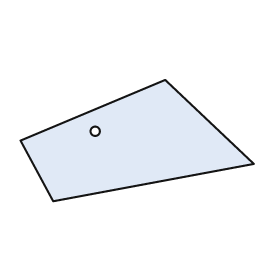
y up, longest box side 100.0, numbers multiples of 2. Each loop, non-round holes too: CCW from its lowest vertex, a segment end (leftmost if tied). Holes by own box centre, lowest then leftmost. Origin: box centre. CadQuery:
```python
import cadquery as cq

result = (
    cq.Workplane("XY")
    .moveTo(-36.0, -26.0)
    .lineTo(50.0, -10.0)
    .lineTo(12.0, 26.0)
    .lineTo(-50.0, 0.0)
    .close()
    .moveTo(-18.0, 4.0)
    .circle(2.0)
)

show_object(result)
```